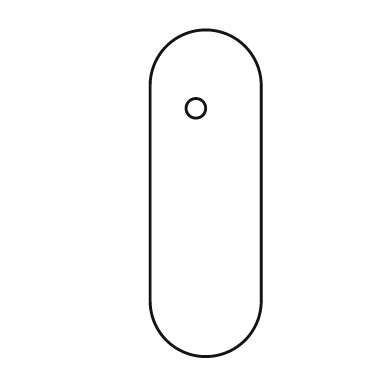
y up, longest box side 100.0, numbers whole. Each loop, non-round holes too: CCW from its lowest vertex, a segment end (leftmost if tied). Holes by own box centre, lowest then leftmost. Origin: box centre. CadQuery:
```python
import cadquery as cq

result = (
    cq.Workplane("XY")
    .moveTo(-17.0, -33.0)
    .threePointArc((0.0, -50.0), (17.0, -33.0))
    .lineTo(17.0, 33.0)
    .threePointArc((0.0, 50.0), (-17.0, 33.0))
    .close()
    .moveTo(-3.0, 26.0)
    .circle(3.0)
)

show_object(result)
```